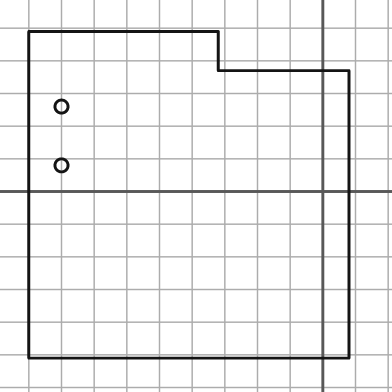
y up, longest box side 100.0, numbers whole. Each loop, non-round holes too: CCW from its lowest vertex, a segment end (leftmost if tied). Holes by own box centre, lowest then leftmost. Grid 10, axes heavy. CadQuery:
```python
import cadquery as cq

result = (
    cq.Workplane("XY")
    .moveTo(-90.0, -51.0)
    .lineTo(8.0, -51.0)
    .lineTo(8.0, 37.0)
    .lineTo(-32.0, 37.0)
    .lineTo(-32.0, 49.0)
    .lineTo(-90.0, 49.0)
    .close()
    .moveTo(-80.0, 8.0)
    .circle(2.0)
    .moveTo(-80.0, 26.0)
    .circle(2.0)
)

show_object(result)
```